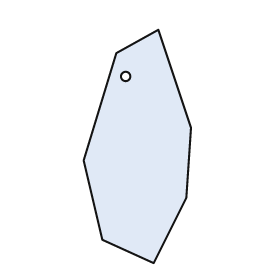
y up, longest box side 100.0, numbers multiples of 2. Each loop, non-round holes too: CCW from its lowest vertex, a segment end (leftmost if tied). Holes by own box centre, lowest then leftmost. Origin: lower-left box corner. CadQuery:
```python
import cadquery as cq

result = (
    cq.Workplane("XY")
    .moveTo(30.0, 0.0)
    .lineTo(44.0, 28.0)
    .lineTo(46.0, 58.0)
    .lineTo(32.0, 100.0)
    .lineTo(14.0, 90.0)
    .lineTo(0.0, 44.0)
    .lineTo(8.0, 10.0)
    .close()
    .moveTo(18.0, 80.0)
    .circle(2.0)
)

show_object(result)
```